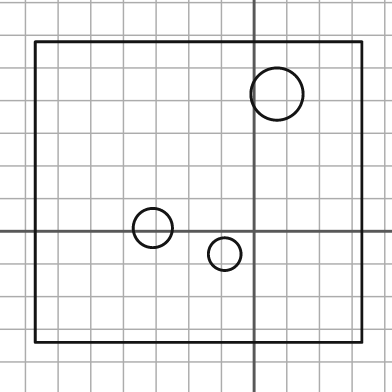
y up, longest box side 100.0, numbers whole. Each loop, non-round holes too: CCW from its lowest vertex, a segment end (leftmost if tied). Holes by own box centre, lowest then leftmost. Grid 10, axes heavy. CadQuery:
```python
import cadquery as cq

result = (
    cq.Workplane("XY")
    .moveTo(-67.0, -34.0)
    .lineTo(33.0, -34.0)
    .lineTo(33.0, 58.0)
    .lineTo(-67.0, 58.0)
    .close()
    .moveTo(-9.0, -7.0)
    .circle(5.0)
    .moveTo(-31.0, 1.0)
    .circle(6.0)
    .moveTo(7.0, 42.0)
    .circle(8.0)
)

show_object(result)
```